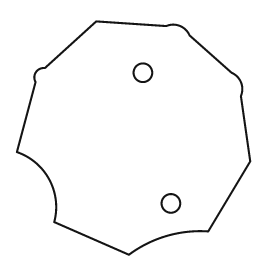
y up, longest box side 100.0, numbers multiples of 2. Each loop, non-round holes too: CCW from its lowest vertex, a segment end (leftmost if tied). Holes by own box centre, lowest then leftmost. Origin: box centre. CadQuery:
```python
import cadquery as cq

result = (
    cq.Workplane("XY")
    .moveTo(-2.0, -50.0)
    .threePointArc((14.0, -42.0), (32.0, -40.0))
    .lineTo(50.0, -10.0)
    .lineTo(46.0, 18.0)
    .threePointArc((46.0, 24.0), (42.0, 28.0))
    .lineTo(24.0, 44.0)
    .threePointArc((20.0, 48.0), (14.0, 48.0))
    .lineTo(-16.0, 50.0)
    .lineTo(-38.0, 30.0)
    .threePointArc((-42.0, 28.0), (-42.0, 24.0))
    .lineTo(-50.0, -6.0)
    .threePointArc((-36.0, -18.0), (-34.0, -36.0))
    .close()
    .moveTo(16.0, -28.0)
    .circle(4.0)
    .moveTo(4.0, 28.0)
    .circle(4.0)
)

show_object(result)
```